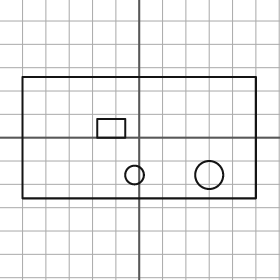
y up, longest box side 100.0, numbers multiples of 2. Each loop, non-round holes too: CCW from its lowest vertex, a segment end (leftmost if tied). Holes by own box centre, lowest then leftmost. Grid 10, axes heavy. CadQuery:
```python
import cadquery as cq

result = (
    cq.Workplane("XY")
    .moveTo(-50.0, -26.0)
    .lineTo(50.0, -26.0)
    .lineTo(50.0, 26.0)
    .lineTo(-50.0, 26.0)
    .close()
    .moveTo(-2.0, -16.0)
    .circle(4.0)
    .moveTo(30.0, -16.0)
    .circle(6.0)
    .moveTo(-18.0, 0.0)
    .lineTo(-6.0, 0.0)
    .lineTo(-6.0, 8.0)
    .lineTo(-18.0, 8.0)
    .close()
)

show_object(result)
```